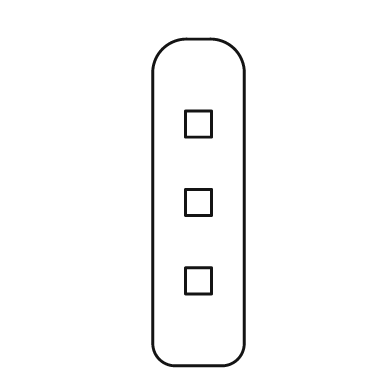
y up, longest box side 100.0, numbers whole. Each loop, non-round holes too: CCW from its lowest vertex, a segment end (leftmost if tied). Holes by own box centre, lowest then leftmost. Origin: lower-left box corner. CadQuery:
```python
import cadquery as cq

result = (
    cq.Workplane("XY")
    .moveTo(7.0, 0.0)
    .lineTo(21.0, 0.0)
    .threePointArc((26.0, 2.0), (28.0, 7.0))
    .lineTo(28.0, 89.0)
    .threePointArc((25.0, 97.0), (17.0, 100.0))
    .lineTo(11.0, 100.0)
    .threePointArc((3.0, 97.0), (0.0, 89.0))
    .lineTo(0.0, 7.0)
    .threePointArc((2.0, 2.0), (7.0, 0.0))
    .close()
    .moveTo(10.0, 22.0)
    .lineTo(18.0, 22.0)
    .lineTo(18.0, 30.0)
    .lineTo(10.0, 30.0)
    .close()
    .moveTo(10.0, 46.0)
    .lineTo(18.0, 46.0)
    .lineTo(18.0, 54.0)
    .lineTo(10.0, 54.0)
    .close()
    .moveTo(10.0, 70.0)
    .lineTo(18.0, 70.0)
    .lineTo(18.0, 78.0)
    .lineTo(10.0, 78.0)
    .close()
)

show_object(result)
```